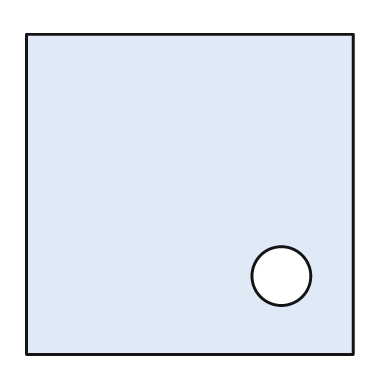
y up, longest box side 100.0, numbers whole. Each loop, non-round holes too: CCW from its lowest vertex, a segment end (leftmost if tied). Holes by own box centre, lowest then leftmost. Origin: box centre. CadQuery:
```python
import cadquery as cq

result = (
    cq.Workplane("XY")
    .moveTo(-50.0, -49.0)
    .lineTo(50.0, -49.0)
    .lineTo(50.0, 49.0)
    .lineTo(-50.0, 49.0)
    .close()
    .moveTo(28.0, -25.0)
    .circle(9.0)
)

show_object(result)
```